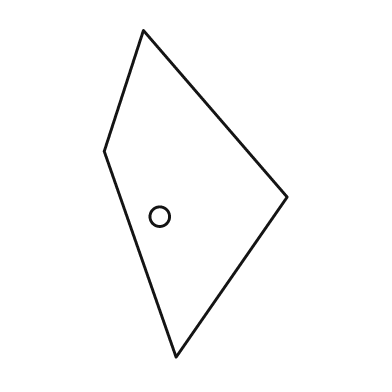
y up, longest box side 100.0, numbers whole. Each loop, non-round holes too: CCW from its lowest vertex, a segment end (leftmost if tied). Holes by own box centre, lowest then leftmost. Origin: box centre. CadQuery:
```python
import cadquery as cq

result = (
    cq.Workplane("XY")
    .moveTo(-6.0, -50.0)
    .lineTo(28.0, -1.0)
    .lineTo(-16.0, 50.0)
    .lineTo(-28.0, 13.0)
    .close()
    .moveTo(-11.0, -7.0)
    .circle(3.0)
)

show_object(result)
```